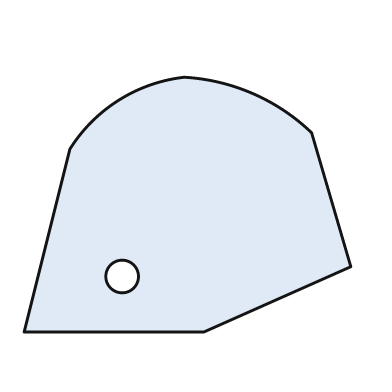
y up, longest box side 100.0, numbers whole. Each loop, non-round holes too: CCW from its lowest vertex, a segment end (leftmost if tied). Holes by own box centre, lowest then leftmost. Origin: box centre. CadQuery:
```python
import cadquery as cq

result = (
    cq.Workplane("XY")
    .moveTo(-50.0, -39.0)
    .lineTo(5.0, -39.0)
    .lineTo(50.0, -19.0)
    .lineTo(38.0, 22.0)
    .threePointArc((20.0, 34.0), (-1.0, 39.0))
    .threePointArc((-21.0, 32.0), (-36.0, 17.0))
    .close()
    .moveTo(-20.0, -22.0)
    .circle(5.0)
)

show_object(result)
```